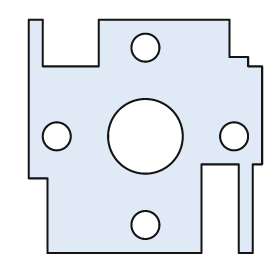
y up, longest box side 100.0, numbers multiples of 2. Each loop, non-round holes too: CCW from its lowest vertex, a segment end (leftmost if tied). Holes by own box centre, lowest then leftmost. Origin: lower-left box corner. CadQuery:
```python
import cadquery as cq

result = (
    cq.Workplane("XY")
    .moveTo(8.0, 0.0)
    .lineTo(74.0, 0.0)
    .lineTo(74.0, 38.0)
    .lineTo(90.0, 38.0)
    .lineTo(90.0, 0.0)
    .lineTo(96.0, 0.0)
    .lineTo(96.0, 38.0)
    .lineTo(100.0, 38.0)
    .lineTo(100.0, 80.0)
    .lineTo(94.0, 80.0)
    .lineTo(94.0, 84.0)
    .lineTo(86.0, 84.0)
    .lineTo(86.0, 100.0)
    .lineTo(30.0, 100.0)
    .lineTo(30.0, 80.0)
    .lineTo(6.0, 80.0)
    .lineTo(6.0, 100.0)
    .lineTo(0.0, 100.0)
    .lineTo(0.0, 32.0)
    .lineTo(8.0, 32.0)
    .close()
    .moveTo(50.0, 12.0)
    .circle(6.0)
    .moveTo(12.0, 50.0)
    .circle(6.0)
    .moveTo(50.0, 50.0)
    .circle(16.0)
    .moveTo(88.0, 50.0)
    .circle(6.0)
    .moveTo(50.0, 88.0)
    .circle(6.0)
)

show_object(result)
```